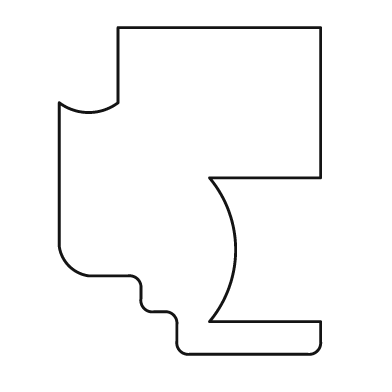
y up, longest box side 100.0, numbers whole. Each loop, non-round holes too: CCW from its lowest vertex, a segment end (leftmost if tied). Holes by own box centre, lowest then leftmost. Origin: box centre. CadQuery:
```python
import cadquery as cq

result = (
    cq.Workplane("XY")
    .moveTo(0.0, -50.0)
    .lineTo(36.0, -50.0)
    .threePointArc((39.0, -49.0), (40.0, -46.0))
    .lineTo(40.0, -40.0)
    .lineTo(6.0, -40.0)
    .threePointArc((14.0, -18.0), (6.0, 4.0))
    .lineTo(40.0, 4.0)
    .lineTo(40.0, 50.0)
    .lineTo(-22.0, 50.0)
    .lineTo(-22.0, 27.0)
    .threePointArc((-31.0, 24.0), (-40.0, 27.0))
    .lineTo(-40.0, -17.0)
    .threePointArc((-37.0, -23.0), (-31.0, -26.0))
    .lineTo(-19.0, -26.0)
    .threePointArc((-16.0, -27.0), (-15.0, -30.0))
    .lineTo(-15.0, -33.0)
    .threePointArc((-14.0, -36.0), (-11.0, -37.0))
    .lineTo(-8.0, -37.0)
    .threePointArc((-5.0, -38.0), (-4.0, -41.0))
    .lineTo(-4.0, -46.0)
    .threePointArc((-3.0, -49.0), (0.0, -50.0))
    .close()
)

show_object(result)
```